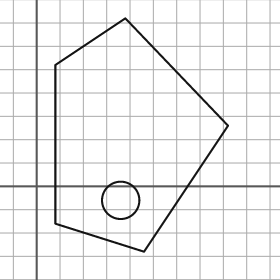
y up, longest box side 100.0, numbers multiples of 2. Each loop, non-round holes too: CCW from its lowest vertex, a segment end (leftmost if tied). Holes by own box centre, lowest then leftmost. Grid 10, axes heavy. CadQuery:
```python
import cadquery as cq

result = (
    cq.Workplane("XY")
    .moveTo(46.0, -28.0)
    .lineTo(82.0, 26.0)
    .lineTo(38.0, 72.0)
    .lineTo(8.0, 52.0)
    .lineTo(8.0, -16.0)
    .close()
    .moveTo(36.0, -6.0)
    .circle(8.0)
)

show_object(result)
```